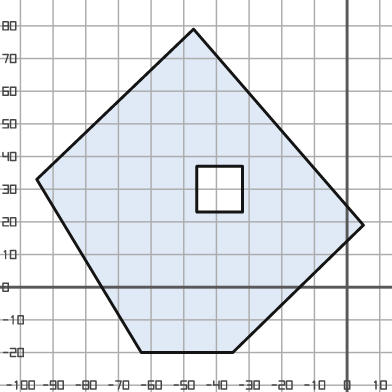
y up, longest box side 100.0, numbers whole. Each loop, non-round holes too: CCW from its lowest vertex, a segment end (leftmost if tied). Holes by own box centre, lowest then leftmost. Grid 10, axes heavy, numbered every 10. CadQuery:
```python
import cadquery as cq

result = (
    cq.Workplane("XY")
    .moveTo(-63.0, -20.0)
    .lineTo(-35.0, -20.0)
    .lineTo(5.0, 19.0)
    .lineTo(-47.0, 79.0)
    .lineTo(-95.0, 33.0)
    .close()
    .moveTo(-46.0, 23.0)
    .lineTo(-32.0, 23.0)
    .lineTo(-32.0, 37.0)
    .lineTo(-46.0, 37.0)
    .close()
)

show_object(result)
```